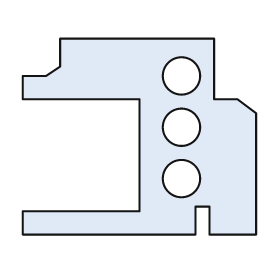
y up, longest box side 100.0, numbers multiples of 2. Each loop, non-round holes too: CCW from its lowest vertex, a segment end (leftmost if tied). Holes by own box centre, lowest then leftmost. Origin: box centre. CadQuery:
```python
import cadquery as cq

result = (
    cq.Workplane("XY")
    .moveTo(-50.0, -42.0)
    .lineTo(24.0, -42.0)
    .lineTo(24.0, -30.0)
    .lineTo(30.0, -30.0)
    .lineTo(30.0, -42.0)
    .lineTo(50.0, -42.0)
    .lineTo(50.0, 10.0)
    .lineTo(42.0, 16.0)
    .lineTo(32.0, 16.0)
    .lineTo(32.0, 42.0)
    .lineTo(-34.0, 42.0)
    .lineTo(-34.0, 30.0)
    .lineTo(-40.0, 26.0)
    .lineTo(-50.0, 26.0)
    .lineTo(-50.0, 16.0)
    .lineTo(0.0, 16.0)
    .lineTo(0.0, -32.0)
    .lineTo(-50.0, -32.0)
    .close()
    .moveTo(18.0, -18.0)
    .circle(8.0)
    .moveTo(18.0, 4.0)
    .circle(8.0)
    .moveTo(18.0, 26.0)
    .circle(8.0)
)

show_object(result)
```